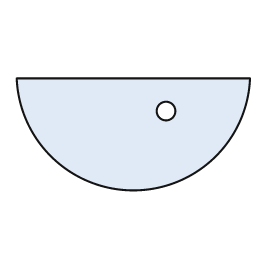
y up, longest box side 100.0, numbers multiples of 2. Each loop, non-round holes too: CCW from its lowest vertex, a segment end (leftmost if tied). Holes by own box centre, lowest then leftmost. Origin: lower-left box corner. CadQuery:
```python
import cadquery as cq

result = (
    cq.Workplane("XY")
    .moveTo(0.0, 48.0)
    .threePointArc((50.0, 0.0), (100.0, 48.0))
    .close()
    .moveTo(64.0, 34.0)
    .circle(4.0)
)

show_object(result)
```